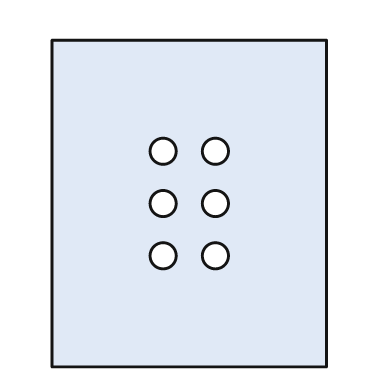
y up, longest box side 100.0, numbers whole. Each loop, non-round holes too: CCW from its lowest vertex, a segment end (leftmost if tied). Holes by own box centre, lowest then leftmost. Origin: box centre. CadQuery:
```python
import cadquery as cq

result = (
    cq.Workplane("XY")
    .moveTo(-42.0, -50.0)
    .lineTo(42.0, -50.0)
    .lineTo(42.0, 50.0)
    .lineTo(-42.0, 50.0)
    .close()
    .moveTo(-8.0, -16.0)
    .circle(4.0)
    .moveTo(8.0, -16.0)
    .circle(4.0)
    .moveTo(-8.0, 0.0)
    .circle(4.0)
    .moveTo(8.0, 0.0)
    .circle(4.0)
    .moveTo(-8.0, 16.0)
    .circle(4.0)
    .moveTo(8.0, 16.0)
    .circle(4.0)
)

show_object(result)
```